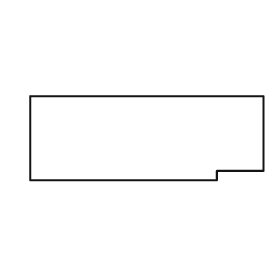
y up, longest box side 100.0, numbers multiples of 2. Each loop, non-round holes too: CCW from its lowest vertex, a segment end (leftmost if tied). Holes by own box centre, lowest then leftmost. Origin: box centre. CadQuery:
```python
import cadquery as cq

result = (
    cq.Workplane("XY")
    .moveTo(-50.0, -18.0)
    .lineTo(30.0, -18.0)
    .lineTo(30.0, -14.0)
    .lineTo(50.0, -14.0)
    .lineTo(50.0, 18.0)
    .lineTo(-50.0, 18.0)
    .close()
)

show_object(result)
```